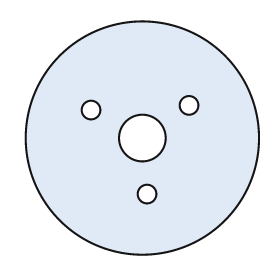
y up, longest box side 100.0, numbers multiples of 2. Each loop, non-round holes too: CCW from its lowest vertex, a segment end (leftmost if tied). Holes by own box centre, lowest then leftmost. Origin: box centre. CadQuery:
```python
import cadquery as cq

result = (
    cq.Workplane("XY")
    .moveTo(0.0, 0.0)
    .circle(50.0)
    .moveTo(2.0, -24.0)
    .circle(4.0)
    .moveTo(0.0, 0.0)
    .circle(10.0)
    .moveTo(-22.0, 12.0)
    .circle(4.0)
    .moveTo(20.0, 14.0)
    .circle(4.0)
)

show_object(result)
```